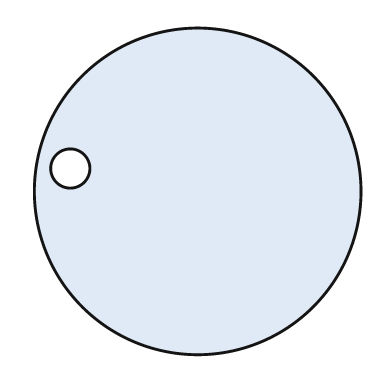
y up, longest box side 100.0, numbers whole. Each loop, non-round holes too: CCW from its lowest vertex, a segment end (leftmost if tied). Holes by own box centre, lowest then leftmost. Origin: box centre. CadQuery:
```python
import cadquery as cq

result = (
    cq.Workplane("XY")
    .moveTo(0.0, 0.0)
    .circle(50.0)
    .moveTo(-39.0, 7.0)
    .circle(6.0)
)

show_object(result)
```